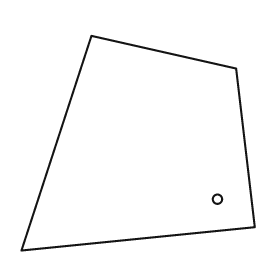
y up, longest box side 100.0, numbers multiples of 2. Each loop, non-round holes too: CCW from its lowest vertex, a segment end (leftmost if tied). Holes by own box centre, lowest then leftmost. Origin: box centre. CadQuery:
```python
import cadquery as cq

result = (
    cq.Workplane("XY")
    .moveTo(-50.0, -46.0)
    .lineTo(50.0, -36.0)
    .lineTo(42.0, 32.0)
    .lineTo(-20.0, 46.0)
    .close()
    .moveTo(34.0, -24.0)
    .circle(2.0)
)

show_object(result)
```